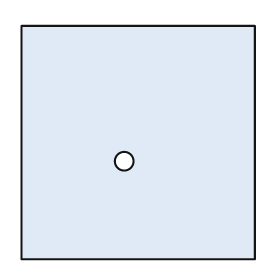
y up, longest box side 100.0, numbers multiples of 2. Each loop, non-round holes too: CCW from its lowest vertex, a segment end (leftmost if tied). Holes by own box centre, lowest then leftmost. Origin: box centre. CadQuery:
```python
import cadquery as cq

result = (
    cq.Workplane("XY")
    .moveTo(-50.0, -50.0)
    .lineTo(50.0, -50.0)
    .lineTo(50.0, 50.0)
    .lineTo(-50.0, 50.0)
    .close()
    .moveTo(-6.0, -8.0)
    .circle(4.0)
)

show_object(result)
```